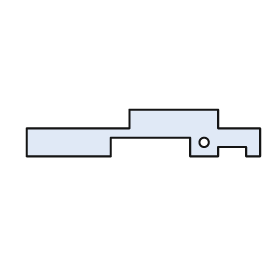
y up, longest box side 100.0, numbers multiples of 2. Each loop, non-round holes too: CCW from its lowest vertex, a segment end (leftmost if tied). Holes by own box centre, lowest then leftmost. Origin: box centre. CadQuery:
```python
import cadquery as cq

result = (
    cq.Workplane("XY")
    .moveTo(-50.0, -10.0)
    .lineTo(-14.0, -10.0)
    .lineTo(-14.0, -2.0)
    .lineTo(20.0, -2.0)
    .lineTo(20.0, -10.0)
    .lineTo(32.0, -10.0)
    .lineTo(32.0, -6.0)
    .lineTo(44.0, -6.0)
    .lineTo(44.0, -10.0)
    .lineTo(50.0, -10.0)
    .lineTo(50.0, 2.0)
    .lineTo(32.0, 2.0)
    .lineTo(32.0, 10.0)
    .lineTo(-6.0, 10.0)
    .lineTo(-6.0, 2.0)
    .lineTo(-50.0, 2.0)
    .close()
    .moveTo(26.0, -4.0)
    .circle(2.0)
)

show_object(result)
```